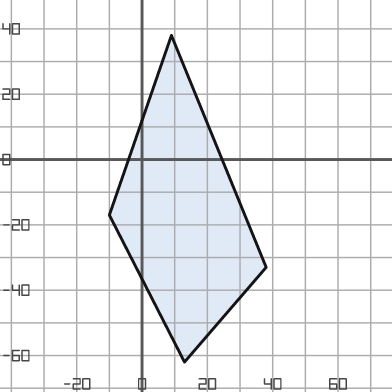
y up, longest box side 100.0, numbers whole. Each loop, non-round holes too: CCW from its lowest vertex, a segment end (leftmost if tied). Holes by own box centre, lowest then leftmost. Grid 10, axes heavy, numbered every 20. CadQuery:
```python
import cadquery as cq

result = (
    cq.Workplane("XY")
    .moveTo(13.0, -62.0)
    .lineTo(38.0, -33.0)
    .lineTo(9.0, 38.0)
    .lineTo(-10.0, -17.0)
    .close()
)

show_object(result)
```